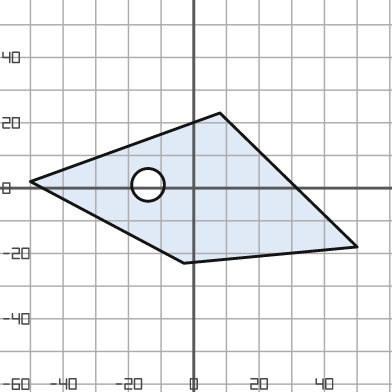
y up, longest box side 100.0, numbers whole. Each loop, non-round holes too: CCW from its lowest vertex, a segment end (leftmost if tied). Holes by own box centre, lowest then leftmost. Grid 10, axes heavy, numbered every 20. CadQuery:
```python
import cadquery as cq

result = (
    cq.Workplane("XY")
    .moveTo(-3.0, -23.0)
    .lineTo(50.0, -18.0)
    .lineTo(8.0, 23.0)
    .lineTo(-50.0, 2.0)
    .close()
    .moveTo(-14.0, 1.0)
    .circle(5.0)
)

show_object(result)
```